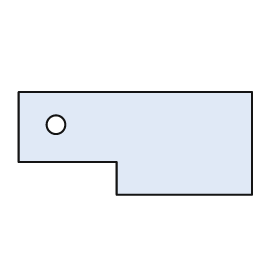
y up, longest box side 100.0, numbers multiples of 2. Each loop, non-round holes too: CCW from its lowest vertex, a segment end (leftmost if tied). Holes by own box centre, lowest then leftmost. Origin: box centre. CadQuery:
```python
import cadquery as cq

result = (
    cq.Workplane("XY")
    .moveTo(-8.0, -22.0)
    .lineTo(50.0, -22.0)
    .lineTo(50.0, 22.0)
    .lineTo(-50.0, 22.0)
    .lineTo(-50.0, -8.0)
    .lineTo(-8.0, -8.0)
    .close()
    .moveTo(-34.0, 8.0)
    .circle(4.0)
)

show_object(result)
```